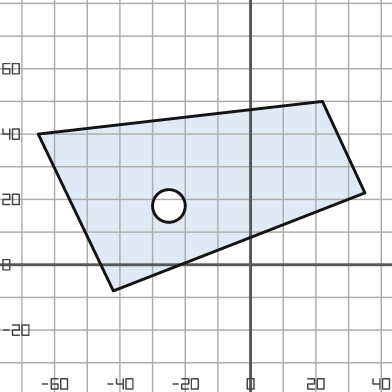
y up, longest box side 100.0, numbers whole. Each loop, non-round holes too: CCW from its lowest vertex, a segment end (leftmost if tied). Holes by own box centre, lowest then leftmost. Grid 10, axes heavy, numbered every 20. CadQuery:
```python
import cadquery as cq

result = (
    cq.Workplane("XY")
    .moveTo(-42.0, -8.0)
    .lineTo(35.0, 22.0)
    .lineTo(22.0, 50.0)
    .lineTo(-65.0, 40.0)
    .close()
    .moveTo(-25.0, 18.0)
    .circle(5.0)
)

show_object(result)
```